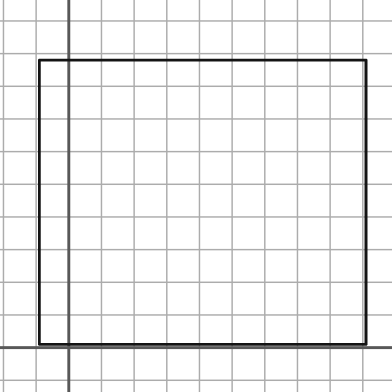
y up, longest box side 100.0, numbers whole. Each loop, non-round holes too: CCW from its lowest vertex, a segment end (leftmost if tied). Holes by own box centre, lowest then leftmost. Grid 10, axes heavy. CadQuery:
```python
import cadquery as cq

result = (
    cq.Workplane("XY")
    .moveTo(-9.0, 1.0)
    .lineTo(91.0, 1.0)
    .lineTo(91.0, 88.0)
    .lineTo(-9.0, 88.0)
    .close()
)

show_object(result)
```